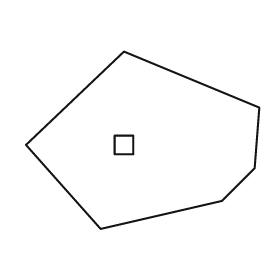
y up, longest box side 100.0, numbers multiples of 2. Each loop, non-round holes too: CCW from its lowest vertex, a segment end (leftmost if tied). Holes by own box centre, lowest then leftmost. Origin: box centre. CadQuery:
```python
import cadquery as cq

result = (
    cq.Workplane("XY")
    .moveTo(-18.0, -38.0)
    .lineTo(34.0, -26.0)
    .lineTo(48.0, -12.0)
    .lineTo(50.0, 14.0)
    .lineTo(-8.0, 38.0)
    .lineTo(-50.0, -2.0)
    .close()
    .moveTo(-12.0, -6.0)
    .lineTo(-4.0, -6.0)
    .lineTo(-4.0, 2.0)
    .lineTo(-12.0, 2.0)
    .close()
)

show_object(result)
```